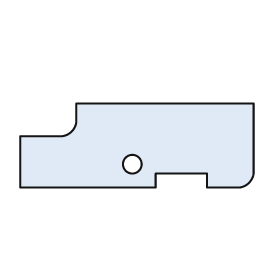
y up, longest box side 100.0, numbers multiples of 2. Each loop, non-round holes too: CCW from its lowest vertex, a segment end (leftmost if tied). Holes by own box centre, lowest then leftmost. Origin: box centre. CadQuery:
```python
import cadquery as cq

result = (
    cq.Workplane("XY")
    .moveTo(-50.0, -18.0)
    .lineTo(8.0, -18.0)
    .lineTo(8.0, -12.0)
    .lineTo(30.0, -12.0)
    .lineTo(30.0, -18.0)
    .lineTo(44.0, -18.0)
    .threePointArc((48.0, -16.0), (50.0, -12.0))
    .lineTo(50.0, 18.0)
    .lineTo(-26.0, 18.0)
    .lineTo(-26.0, 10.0)
    .threePointArc((-28.0, 6.0), (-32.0, 4.0))
    .lineTo(-50.0, 4.0)
    .close()
    .moveTo(-2.0, -8.0)
    .circle(4.0)
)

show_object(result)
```